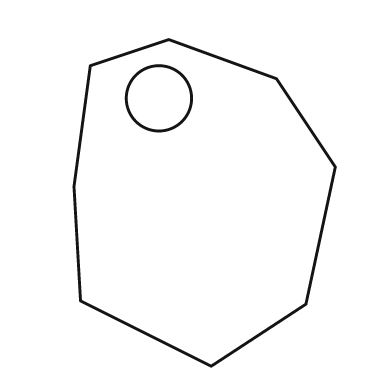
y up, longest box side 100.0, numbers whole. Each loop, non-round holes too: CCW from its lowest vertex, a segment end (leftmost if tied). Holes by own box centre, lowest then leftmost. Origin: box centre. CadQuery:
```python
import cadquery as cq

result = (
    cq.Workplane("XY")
    .moveTo(2.0, -50.0)
    .lineTo(31.0, -31.0)
    .lineTo(40.0, 11.0)
    .lineTo(22.0, 38.0)
    .lineTo(-11.0, 50.0)
    .lineTo(-35.0, 42.0)
    .lineTo(-40.0, 5.0)
    .lineTo(-38.0, -30.0)
    .close()
    .moveTo(-14.0, 32.0)
    .circle(10.0)
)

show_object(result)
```